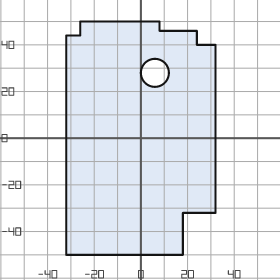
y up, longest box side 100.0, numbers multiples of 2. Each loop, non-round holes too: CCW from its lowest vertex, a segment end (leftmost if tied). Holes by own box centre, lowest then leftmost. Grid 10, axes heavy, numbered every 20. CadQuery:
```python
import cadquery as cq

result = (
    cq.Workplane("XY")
    .moveTo(-32.0, -50.0)
    .lineTo(18.0, -50.0)
    .lineTo(18.0, -32.0)
    .lineTo(32.0, -32.0)
    .lineTo(32.0, 40.0)
    .lineTo(24.0, 40.0)
    .lineTo(24.0, 46.0)
    .lineTo(8.0, 46.0)
    .lineTo(8.0, 50.0)
    .lineTo(-26.0, 50.0)
    .lineTo(-26.0, 44.0)
    .lineTo(-32.0, 44.0)
    .close()
    .moveTo(6.0, 28.0)
    .circle(6.0)
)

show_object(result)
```